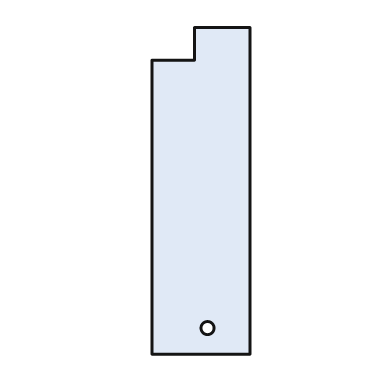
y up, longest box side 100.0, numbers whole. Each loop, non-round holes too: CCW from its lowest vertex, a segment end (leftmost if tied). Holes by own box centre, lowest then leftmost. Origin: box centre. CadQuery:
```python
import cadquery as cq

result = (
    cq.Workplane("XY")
    .moveTo(-15.0, -50.0)
    .lineTo(15.0, -50.0)
    .lineTo(15.0, 50.0)
    .lineTo(-2.0, 50.0)
    .lineTo(-2.0, 40.0)
    .lineTo(-15.0, 40.0)
    .close()
    .moveTo(2.0, -42.0)
    .circle(2.0)
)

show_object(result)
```